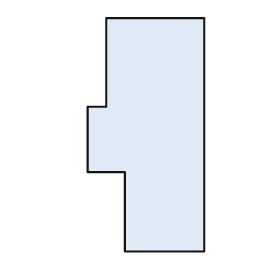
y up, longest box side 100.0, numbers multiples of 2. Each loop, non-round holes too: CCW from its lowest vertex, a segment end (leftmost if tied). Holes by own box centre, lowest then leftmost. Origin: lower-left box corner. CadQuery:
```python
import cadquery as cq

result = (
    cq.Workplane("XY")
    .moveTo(16.0, 0.0)
    .lineTo(50.0, 0.0)
    .lineTo(50.0, 100.0)
    .lineTo(8.0, 100.0)
    .lineTo(8.0, 62.0)
    .lineTo(0.0, 62.0)
    .lineTo(0.0, 34.0)
    .lineTo(16.0, 34.0)
    .close()
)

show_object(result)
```